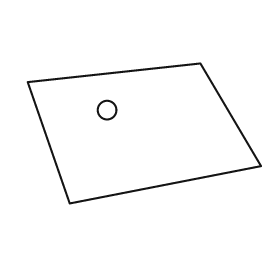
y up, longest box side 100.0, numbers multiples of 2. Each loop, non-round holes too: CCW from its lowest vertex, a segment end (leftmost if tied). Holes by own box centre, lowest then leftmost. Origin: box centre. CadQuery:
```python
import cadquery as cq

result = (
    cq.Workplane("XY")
    .moveTo(-32.0, -30.0)
    .lineTo(50.0, -14.0)
    .lineTo(24.0, 30.0)
    .lineTo(-50.0, 22.0)
    .close()
    .moveTo(-16.0, 10.0)
    .circle(4.0)
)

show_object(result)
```